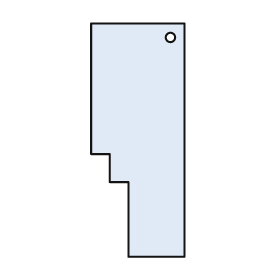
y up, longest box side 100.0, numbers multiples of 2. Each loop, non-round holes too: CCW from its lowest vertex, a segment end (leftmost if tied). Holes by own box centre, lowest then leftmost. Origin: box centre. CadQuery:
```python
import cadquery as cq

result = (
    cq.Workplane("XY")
    .moveTo(-4.0, -50.0)
    .lineTo(20.0, -50.0)
    .lineTo(20.0, 50.0)
    .lineTo(-20.0, 50.0)
    .lineTo(-20.0, -6.0)
    .lineTo(-12.0, -6.0)
    .lineTo(-12.0, -18.0)
    .lineTo(-4.0, -18.0)
    .close()
    .moveTo(14.0, 44.0)
    .circle(2.0)
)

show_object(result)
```